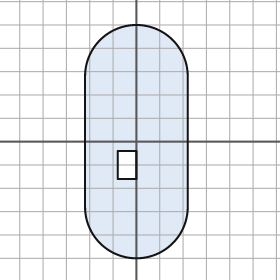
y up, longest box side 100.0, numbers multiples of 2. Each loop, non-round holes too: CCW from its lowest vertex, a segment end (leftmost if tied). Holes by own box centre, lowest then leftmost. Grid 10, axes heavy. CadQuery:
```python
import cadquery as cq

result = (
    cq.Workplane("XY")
    .moveTo(-22.0, -28.0)
    .threePointArc((0.0, -50.0), (22.0, -28.0))
    .lineTo(22.0, 28.0)
    .threePointArc((0.0, 50.0), (-22.0, 28.0))
    .close()
    .moveTo(-8.0, -16.0)
    .lineTo(0.0, -16.0)
    .lineTo(0.0, -4.0)
    .lineTo(-8.0, -4.0)
    .close()
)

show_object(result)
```